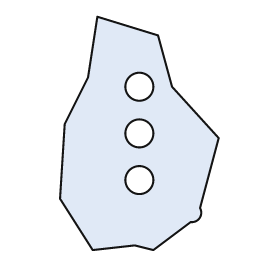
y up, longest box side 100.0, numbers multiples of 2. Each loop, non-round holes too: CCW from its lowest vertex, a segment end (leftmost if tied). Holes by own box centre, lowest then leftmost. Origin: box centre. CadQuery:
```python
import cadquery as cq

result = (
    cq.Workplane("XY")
    .moveTo(-20.0, -50.0)
    .lineTo(-2.0, -48.0)
    .lineTo(6.0, -50.0)
    .lineTo(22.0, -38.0)
    .threePointArc((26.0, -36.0), (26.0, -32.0))
    .lineTo(34.0, -2.0)
    .lineTo(14.0, 20.0)
    .lineTo(8.0, 42.0)
    .lineTo(-18.0, 50.0)
    .lineTo(-22.0, 24.0)
    .lineTo(-32.0, 4.0)
    .lineTo(-34.0, -28.0)
    .close()
    .moveTo(0.0, -20.0)
    .circle(6.0)
    .moveTo(0.0, 0.0)
    .circle(6.0)
    .moveTo(0.0, 20.0)
    .circle(6.0)
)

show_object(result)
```